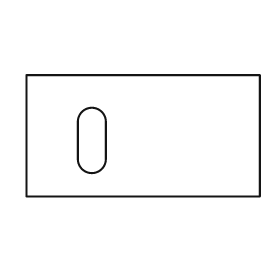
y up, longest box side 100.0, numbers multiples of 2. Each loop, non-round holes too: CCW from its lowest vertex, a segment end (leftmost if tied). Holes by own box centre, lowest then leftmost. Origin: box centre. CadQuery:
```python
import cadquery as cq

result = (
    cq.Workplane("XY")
    .moveTo(-50.0, -26.0)
    .lineTo(50.0, -26.0)
    .lineTo(50.0, 26.0)
    .lineTo(-50.0, 26.0)
    .close()
    .moveTo(-28.0, -10.0)
    .threePointArc((-22.0, -16.0), (-16.0, -10.0))
    .lineTo(-16.0, 6.0)
    .threePointArc((-22.0, 12.0), (-28.0, 6.0))
    .close()
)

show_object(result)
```